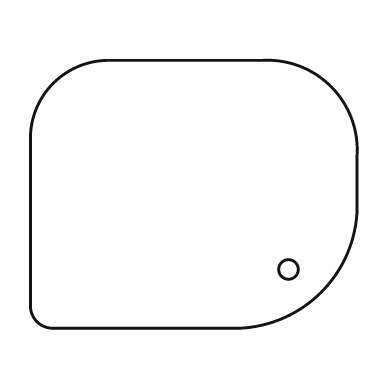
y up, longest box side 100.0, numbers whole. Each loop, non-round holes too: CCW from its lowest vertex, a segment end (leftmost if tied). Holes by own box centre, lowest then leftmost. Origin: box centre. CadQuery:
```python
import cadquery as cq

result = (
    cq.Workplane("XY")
    .moveTo(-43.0, -41.0)
    .lineTo(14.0, -41.0)
    .threePointArc((39.0, -30.0), (50.0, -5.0))
    .lineTo(50.0, 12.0)
    .threePointArc((42.0, 33.0), (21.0, 41.0))
    .lineTo(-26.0, 41.0)
    .threePointArc((-43.0, 34.0), (-50.0, 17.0))
    .lineTo(-50.0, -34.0)
    .threePointArc((-48.0, -39.0), (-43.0, -41.0))
    .close()
    .moveTo(29.0, -23.0)
    .circle(3.0)
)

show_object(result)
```